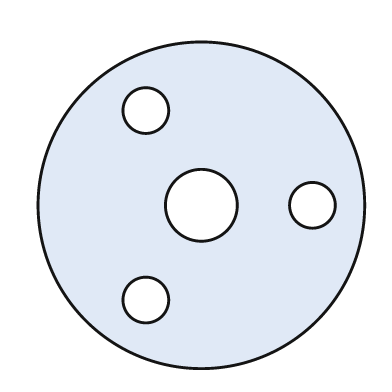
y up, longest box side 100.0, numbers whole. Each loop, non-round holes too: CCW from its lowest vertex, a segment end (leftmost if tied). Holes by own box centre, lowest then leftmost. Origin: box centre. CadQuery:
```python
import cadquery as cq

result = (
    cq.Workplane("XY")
    .moveTo(0.0, 0.0)
    .circle(50.0)
    .moveTo(-17.0, -29.0)
    .circle(7.0)
    .moveTo(0.0, 0.0)
    .circle(11.0)
    .moveTo(34.0, 0.0)
    .circle(7.0)
    .moveTo(-17.0, 29.0)
    .circle(7.0)
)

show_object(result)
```